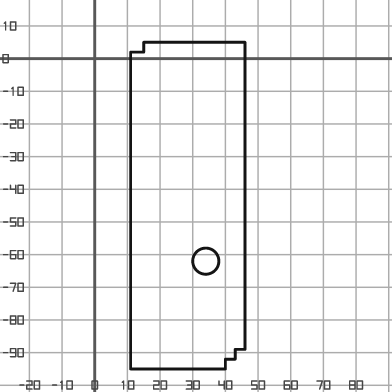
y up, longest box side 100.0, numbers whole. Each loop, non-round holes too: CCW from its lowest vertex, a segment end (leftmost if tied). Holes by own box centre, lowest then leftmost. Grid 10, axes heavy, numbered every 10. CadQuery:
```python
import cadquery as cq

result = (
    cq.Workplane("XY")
    .moveTo(11.0, -95.0)
    .lineTo(40.0, -95.0)
    .lineTo(40.0, -92.0)
    .lineTo(43.0, -92.0)
    .lineTo(43.0, -89.0)
    .lineTo(46.0, -89.0)
    .lineTo(46.0, 5.0)
    .lineTo(15.0, 5.0)
    .lineTo(15.0, 2.0)
    .lineTo(11.0, 2.0)
    .close()
    .moveTo(34.0, -62.0)
    .circle(4.0)
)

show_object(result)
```